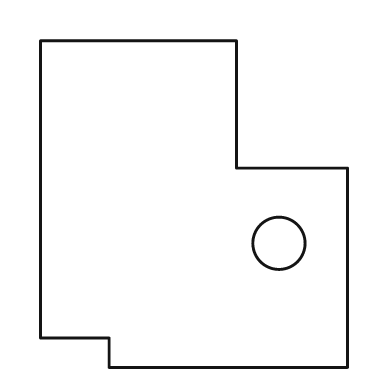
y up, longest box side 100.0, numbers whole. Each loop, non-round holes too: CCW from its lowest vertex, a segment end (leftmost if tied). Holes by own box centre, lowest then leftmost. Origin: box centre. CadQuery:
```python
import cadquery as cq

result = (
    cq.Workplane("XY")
    .moveTo(-26.0, -50.0)
    .lineTo(47.0, -50.0)
    .lineTo(47.0, 11.0)
    .lineTo(13.0, 11.0)
    .lineTo(13.0, 50.0)
    .lineTo(-47.0, 50.0)
    .lineTo(-47.0, -41.0)
    .lineTo(-26.0, -41.0)
    .close()
    .moveTo(26.0, -12.0)
    .circle(8.0)
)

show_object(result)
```